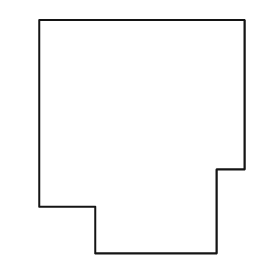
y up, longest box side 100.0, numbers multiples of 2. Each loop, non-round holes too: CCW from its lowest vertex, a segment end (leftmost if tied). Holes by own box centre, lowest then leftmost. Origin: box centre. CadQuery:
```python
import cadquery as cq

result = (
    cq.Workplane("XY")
    .moveTo(-20.0, -50.0)
    .lineTo(32.0, -50.0)
    .lineTo(32.0, -14.0)
    .lineTo(44.0, -14.0)
    .lineTo(44.0, 50.0)
    .lineTo(-44.0, 50.0)
    .lineTo(-44.0, -30.0)
    .lineTo(-20.0, -30.0)
    .close()
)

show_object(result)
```